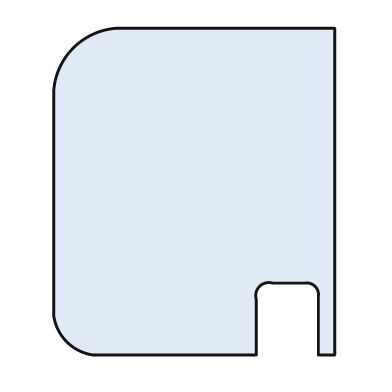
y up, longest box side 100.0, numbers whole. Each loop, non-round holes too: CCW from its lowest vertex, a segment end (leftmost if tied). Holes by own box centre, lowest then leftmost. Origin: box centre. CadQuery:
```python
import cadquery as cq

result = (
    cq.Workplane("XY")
    .moveTo(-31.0, -50.0)
    .lineTo(19.0, -50.0)
    .lineTo(19.0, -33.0)
    .threePointArc((20.0, -29.0), (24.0, -28.0))
    .lineTo(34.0, -28.0)
    .threePointArc((37.0, -29.0), (38.0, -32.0))
    .lineTo(38.0, -50.0)
    .lineTo(43.0, -50.0)
    .lineTo(43.0, 50.0)
    .lineTo(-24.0, 50.0)
    .threePointArc((-37.0, 44.0), (-43.0, 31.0))
    .lineTo(-43.0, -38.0)
    .threePointArc((-39.0, -46.0), (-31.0, -50.0))
    .close()
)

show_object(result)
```